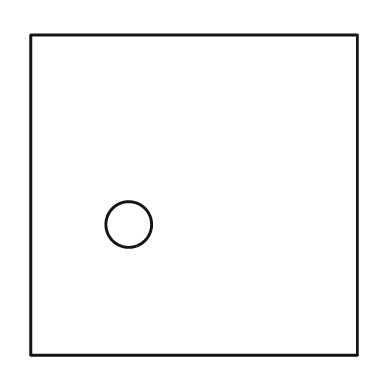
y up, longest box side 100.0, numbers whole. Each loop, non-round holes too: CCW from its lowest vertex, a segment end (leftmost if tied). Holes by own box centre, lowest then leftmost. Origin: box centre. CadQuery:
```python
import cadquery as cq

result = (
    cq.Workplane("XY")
    .moveTo(-50.0, -49.0)
    .lineTo(50.0, -49.0)
    .lineTo(50.0, 49.0)
    .lineTo(-50.0, 49.0)
    .close()
    .moveTo(-20.0, -9.0)
    .circle(7.0)
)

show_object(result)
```